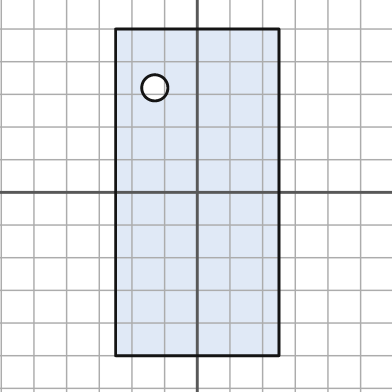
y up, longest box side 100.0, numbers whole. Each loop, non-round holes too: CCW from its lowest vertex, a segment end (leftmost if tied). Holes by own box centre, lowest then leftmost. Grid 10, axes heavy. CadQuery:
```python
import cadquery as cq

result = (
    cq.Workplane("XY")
    .moveTo(-25.0, -50.0)
    .lineTo(25.0, -50.0)
    .lineTo(25.0, 50.0)
    .lineTo(-25.0, 50.0)
    .close()
    .moveTo(-13.0, 32.0)
    .circle(4.0)
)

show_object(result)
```